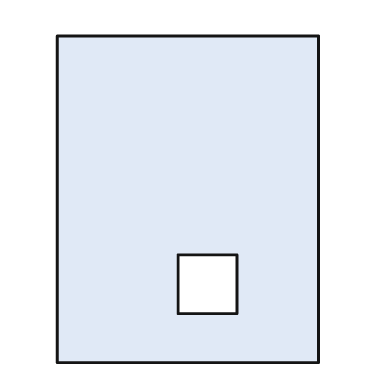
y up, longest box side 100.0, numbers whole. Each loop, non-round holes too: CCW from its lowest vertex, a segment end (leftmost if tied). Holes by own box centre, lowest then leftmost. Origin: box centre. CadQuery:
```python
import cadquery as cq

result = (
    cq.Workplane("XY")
    .moveTo(-40.0, -50.0)
    .lineTo(40.0, -50.0)
    .lineTo(40.0, 50.0)
    .lineTo(-40.0, 50.0)
    .close()
    .moveTo(-3.0, -35.0)
    .lineTo(15.0, -35.0)
    .lineTo(15.0, -17.0)
    .lineTo(-3.0, -17.0)
    .close()
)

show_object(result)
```